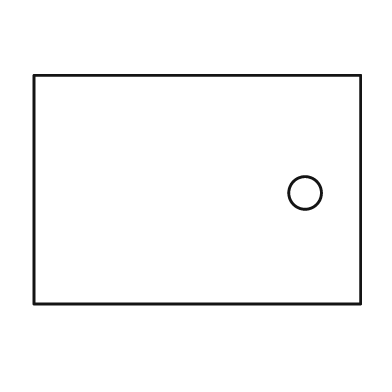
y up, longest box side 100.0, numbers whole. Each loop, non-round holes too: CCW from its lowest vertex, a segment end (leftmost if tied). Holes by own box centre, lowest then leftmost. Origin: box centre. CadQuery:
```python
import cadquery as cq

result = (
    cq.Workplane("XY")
    .moveTo(-50.0, -35.0)
    .lineTo(50.0, -35.0)
    .lineTo(50.0, 35.0)
    .lineTo(-50.0, 35.0)
    .close()
    .moveTo(33.0, -1.0)
    .circle(5.0)
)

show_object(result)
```